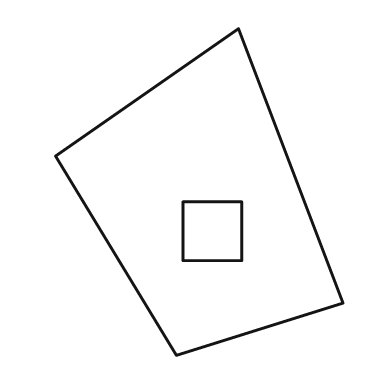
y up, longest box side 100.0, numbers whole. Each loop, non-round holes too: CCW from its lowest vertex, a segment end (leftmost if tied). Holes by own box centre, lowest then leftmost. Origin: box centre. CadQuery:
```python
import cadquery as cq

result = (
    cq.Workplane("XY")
    .moveTo(-7.0, -50.0)
    .lineTo(44.0, -34.0)
    .lineTo(12.0, 50.0)
    .lineTo(-44.0, 11.0)
    .close()
    .moveTo(-5.0, -21.0)
    .lineTo(13.0, -21.0)
    .lineTo(13.0, -3.0)
    .lineTo(-5.0, -3.0)
    .close()
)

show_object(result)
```